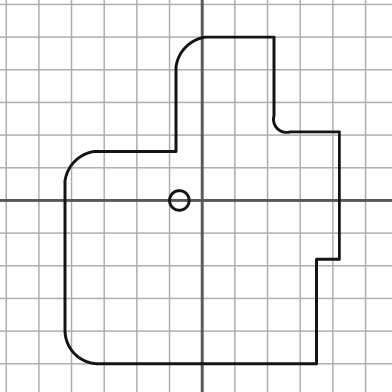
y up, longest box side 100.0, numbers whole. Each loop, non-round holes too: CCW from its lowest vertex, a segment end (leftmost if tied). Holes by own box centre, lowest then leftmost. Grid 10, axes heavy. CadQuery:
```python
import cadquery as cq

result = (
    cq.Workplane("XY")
    .moveTo(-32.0, -50.0)
    .lineTo(35.0, -50.0)
    .lineTo(35.0, -18.0)
    .lineTo(42.0, -18.0)
    .lineTo(42.0, 21.0)
    .lineTo(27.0, 21.0)
    .threePointArc((23.0, 22.0), (22.0, 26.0))
    .lineTo(22.0, 50.0)
    .lineTo(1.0, 50.0)
    .threePointArc((-5.0, 47.0), (-8.0, 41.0))
    .lineTo(-8.0, 15.0)
    .lineTo(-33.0, 15.0)
    .threePointArc((-39.0, 12.0), (-42.0, 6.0))
    .lineTo(-42.0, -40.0)
    .threePointArc((-39.0, -47.0), (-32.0, -50.0))
    .close()
    .moveTo(-7.0, 0.0)
    .circle(3.0)
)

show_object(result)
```